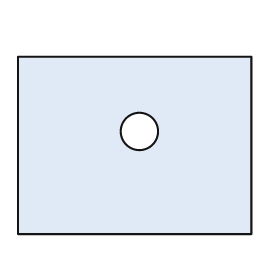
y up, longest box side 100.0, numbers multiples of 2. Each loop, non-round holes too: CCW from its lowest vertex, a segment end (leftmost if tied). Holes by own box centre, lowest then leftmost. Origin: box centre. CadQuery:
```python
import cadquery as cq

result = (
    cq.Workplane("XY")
    .moveTo(-50.0, -38.0)
    .lineTo(50.0, -38.0)
    .lineTo(50.0, 38.0)
    .lineTo(-50.0, 38.0)
    .close()
    .moveTo(2.0, 6.0)
    .circle(8.0)
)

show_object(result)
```